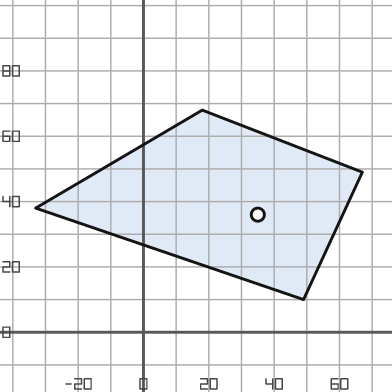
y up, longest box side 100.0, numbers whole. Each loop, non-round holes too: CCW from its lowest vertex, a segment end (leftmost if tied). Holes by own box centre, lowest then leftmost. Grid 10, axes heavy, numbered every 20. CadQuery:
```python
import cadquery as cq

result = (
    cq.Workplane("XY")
    .moveTo(49.0, 10.0)
    .lineTo(67.0, 49.0)
    .lineTo(18.0, 68.0)
    .lineTo(-33.0, 38.0)
    .close()
    .moveTo(35.0, 36.0)
    .circle(2.0)
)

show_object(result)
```